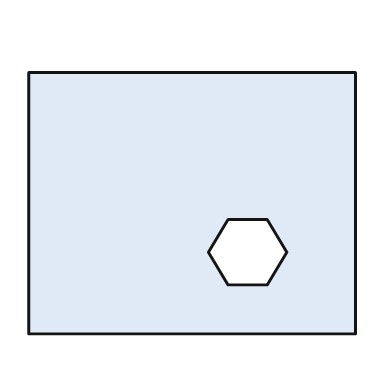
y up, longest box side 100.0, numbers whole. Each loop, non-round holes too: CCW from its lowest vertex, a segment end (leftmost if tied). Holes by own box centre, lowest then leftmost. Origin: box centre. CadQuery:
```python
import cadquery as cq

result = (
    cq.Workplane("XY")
    .moveTo(-50.0, -40.0)
    .lineTo(50.0, -40.0)
    .lineTo(50.0, 40.0)
    .lineTo(-50.0, 40.0)
    .close()
    .moveTo(11.0, -25.0)
    .lineTo(23.0, -25.0)
    .lineTo(29.0, -15.0)
    .lineTo(23.0, -5.0)
    .lineTo(11.0, -5.0)
    .lineTo(5.0, -15.0)
    .close()
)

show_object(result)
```